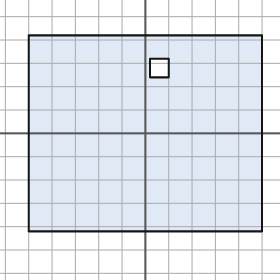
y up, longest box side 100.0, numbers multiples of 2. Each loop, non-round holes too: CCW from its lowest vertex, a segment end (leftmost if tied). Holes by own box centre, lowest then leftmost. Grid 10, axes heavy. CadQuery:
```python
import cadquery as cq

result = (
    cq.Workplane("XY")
    .moveTo(-50.0, -42.0)
    .lineTo(50.0, -42.0)
    .lineTo(50.0, 42.0)
    .lineTo(-50.0, 42.0)
    .close()
    .moveTo(2.0, 24.0)
    .lineTo(10.0, 24.0)
    .lineTo(10.0, 32.0)
    .lineTo(2.0, 32.0)
    .close()
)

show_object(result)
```